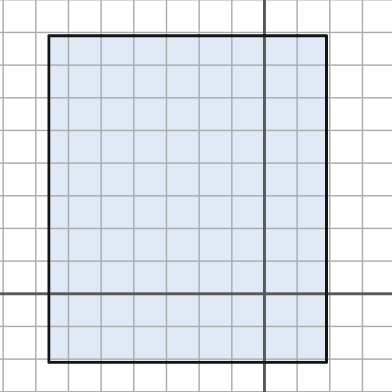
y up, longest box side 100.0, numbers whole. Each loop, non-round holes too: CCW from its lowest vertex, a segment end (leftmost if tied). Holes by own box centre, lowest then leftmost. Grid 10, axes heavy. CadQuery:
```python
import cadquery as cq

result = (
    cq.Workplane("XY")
    .moveTo(-66.0, -21.0)
    .lineTo(19.0, -21.0)
    .lineTo(19.0, 79.0)
    .lineTo(-66.0, 79.0)
    .close()
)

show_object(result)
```